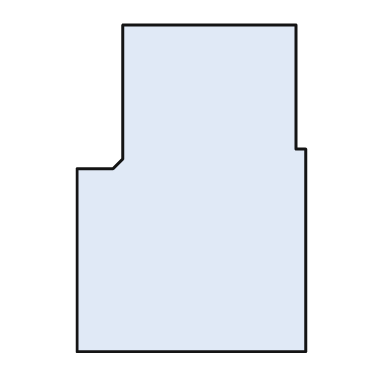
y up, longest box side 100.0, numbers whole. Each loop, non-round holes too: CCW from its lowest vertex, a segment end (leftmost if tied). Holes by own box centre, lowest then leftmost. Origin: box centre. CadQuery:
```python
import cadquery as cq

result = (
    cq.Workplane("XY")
    .moveTo(-35.0, -50.0)
    .lineTo(35.0, -50.0)
    .lineTo(35.0, 12.0)
    .lineTo(32.0, 12.0)
    .lineTo(32.0, 50.0)
    .lineTo(-21.0, 50.0)
    .lineTo(-21.0, 9.0)
    .lineTo(-24.0, 6.0)
    .lineTo(-35.0, 6.0)
    .close()
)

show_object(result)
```